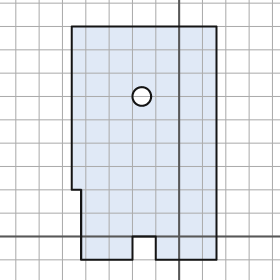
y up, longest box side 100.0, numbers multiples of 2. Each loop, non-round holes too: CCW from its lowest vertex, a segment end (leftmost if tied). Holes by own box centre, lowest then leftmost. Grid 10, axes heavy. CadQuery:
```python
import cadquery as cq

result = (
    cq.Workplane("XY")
    .moveTo(-42.0, -10.0)
    .lineTo(-20.0, -10.0)
    .lineTo(-20.0, 0.0)
    .lineTo(-10.0, 0.0)
    .lineTo(-10.0, -10.0)
    .lineTo(16.0, -10.0)
    .lineTo(16.0, 90.0)
    .lineTo(-46.0, 90.0)
    .lineTo(-46.0, 20.0)
    .lineTo(-42.0, 20.0)
    .close()
    .moveTo(-16.0, 60.0)
    .circle(4.0)
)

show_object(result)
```